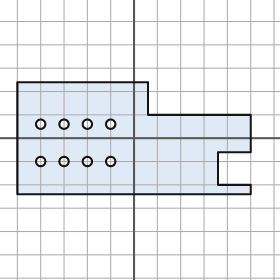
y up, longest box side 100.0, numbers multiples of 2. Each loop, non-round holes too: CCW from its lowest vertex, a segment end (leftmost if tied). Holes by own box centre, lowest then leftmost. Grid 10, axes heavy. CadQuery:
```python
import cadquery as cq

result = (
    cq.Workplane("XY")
    .moveTo(-50.0, -24.0)
    .lineTo(50.0, -24.0)
    .lineTo(50.0, -20.0)
    .lineTo(36.0, -20.0)
    .lineTo(36.0, -6.0)
    .lineTo(50.0, -6.0)
    .lineTo(50.0, 10.0)
    .lineTo(6.0, 10.0)
    .lineTo(6.0, 24.0)
    .lineTo(-50.0, 24.0)
    .close()
    .moveTo(-40.0, -10.0)
    .circle(2.0)
    .moveTo(-30.0, -10.0)
    .circle(2.0)
    .moveTo(-20.0, -10.0)
    .circle(2.0)
    .moveTo(-10.0, -10.0)
    .circle(2.0)
    .moveTo(-40.0, 6.0)
    .circle(2.0)
    .moveTo(-30.0, 6.0)
    .circle(2.0)
    .moveTo(-20.0, 6.0)
    .circle(2.0)
    .moveTo(-10.0, 6.0)
    .circle(2.0)
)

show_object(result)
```